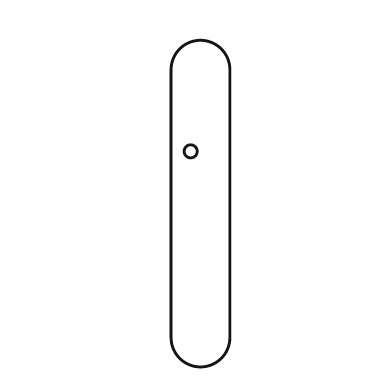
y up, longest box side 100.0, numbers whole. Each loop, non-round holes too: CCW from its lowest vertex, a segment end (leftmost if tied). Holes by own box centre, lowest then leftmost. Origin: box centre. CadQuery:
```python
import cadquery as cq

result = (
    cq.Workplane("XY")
    .moveTo(-9.0, -41.0)
    .threePointArc((0.0, -50.0), (9.0, -41.0))
    .lineTo(9.0, 41.0)
    .threePointArc((0.0, 50.0), (-9.0, 41.0))
    .close()
    .moveTo(-3.0, 16.0)
    .circle(2.0)
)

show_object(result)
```